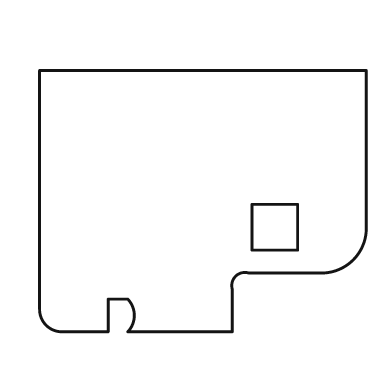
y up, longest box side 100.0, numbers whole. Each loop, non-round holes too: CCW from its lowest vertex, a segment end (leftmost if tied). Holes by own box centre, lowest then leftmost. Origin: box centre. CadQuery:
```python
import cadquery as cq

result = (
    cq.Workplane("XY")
    .moveTo(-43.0, -40.0)
    .lineTo(-29.0, -40.0)
    .lineTo(-29.0, -30.0)
    .lineTo(-23.0, -30.0)
    .threePointArc((-21.0, -35.0), (-23.0, -40.0))
    .lineTo(9.0, -40.0)
    .lineTo(9.0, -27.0)
    .threePointArc((10.0, -23.0), (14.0, -22.0))
    .lineTo(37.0, -22.0)
    .threePointArc((46.0, -18.0), (50.0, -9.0))
    .lineTo(50.0, 40.0)
    .lineTo(-50.0, 40.0)
    .lineTo(-50.0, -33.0)
    .threePointArc((-48.0, -38.0), (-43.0, -40.0))
    .close()
    .moveTo(15.0, -15.0)
    .lineTo(29.0, -15.0)
    .lineTo(29.0, -1.0)
    .lineTo(15.0, -1.0)
    .close()
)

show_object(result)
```